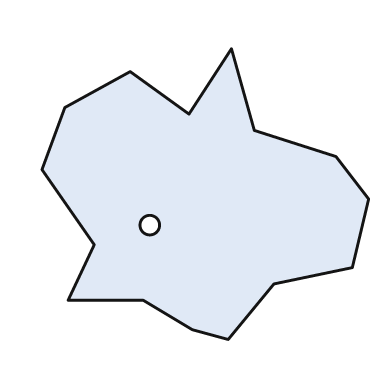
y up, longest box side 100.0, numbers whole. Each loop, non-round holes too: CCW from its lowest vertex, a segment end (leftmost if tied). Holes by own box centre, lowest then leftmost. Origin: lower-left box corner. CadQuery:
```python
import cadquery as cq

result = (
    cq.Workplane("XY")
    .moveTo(57.0, 0.0)
    .lineTo(71.0, 17.0)
    .lineTo(95.0, 22.0)
    .lineTo(100.0, 43.0)
    .lineTo(90.0, 56.0)
    .lineTo(65.0, 64.0)
    .lineTo(58.0, 89.0)
    .lineTo(45.0, 69.0)
    .lineTo(27.0, 82.0)
    .lineTo(7.0, 71.0)
    .lineTo(0.0, 52.0)
    .lineTo(16.0, 29.0)
    .lineTo(8.0, 12.0)
    .lineTo(31.0, 12.0)
    .lineTo(46.0, 3.0)
    .close()
    .moveTo(33.0, 35.0)
    .circle(3.0)
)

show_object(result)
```